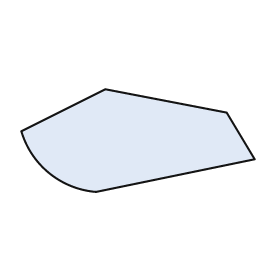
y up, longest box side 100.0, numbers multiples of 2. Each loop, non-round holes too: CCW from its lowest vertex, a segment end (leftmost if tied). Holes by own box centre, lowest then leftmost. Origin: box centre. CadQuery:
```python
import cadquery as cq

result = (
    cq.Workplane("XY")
    .moveTo(-18.0, -22.0)
    .lineTo(50.0, -8.0)
    .lineTo(38.0, 12.0)
    .lineTo(-14.0, 22.0)
    .lineTo(-50.0, 4.0)
    .threePointArc((-38.0, -14.0), (-18.0, -22.0))
    .close()
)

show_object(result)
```